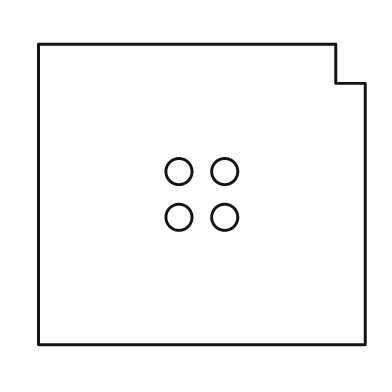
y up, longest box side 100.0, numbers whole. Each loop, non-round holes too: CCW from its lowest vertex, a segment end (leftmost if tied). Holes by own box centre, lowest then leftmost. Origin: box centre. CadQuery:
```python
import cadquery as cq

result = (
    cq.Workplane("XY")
    .moveTo(-50.0, -46.0)
    .lineTo(50.0, -46.0)
    .lineTo(50.0, 34.0)
    .lineTo(41.0, 34.0)
    .lineTo(41.0, 46.0)
    .lineTo(-50.0, 46.0)
    .close()
    .moveTo(-7.0, -7.0)
    .circle(4.0)
    .moveTo(7.0, -7.0)
    .circle(4.0)
    .moveTo(-7.0, 7.0)
    .circle(4.0)
    .moveTo(7.0, 7.0)
    .circle(4.0)
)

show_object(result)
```